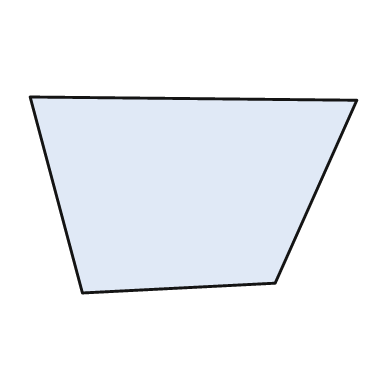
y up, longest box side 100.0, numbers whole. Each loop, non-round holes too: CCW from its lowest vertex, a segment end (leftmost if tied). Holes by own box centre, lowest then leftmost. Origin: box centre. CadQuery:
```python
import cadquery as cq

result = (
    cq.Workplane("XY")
    .moveTo(-34.0, -30.0)
    .lineTo(25.0, -27.0)
    .lineTo(50.0, 29.0)
    .lineTo(-50.0, 30.0)
    .close()
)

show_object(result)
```